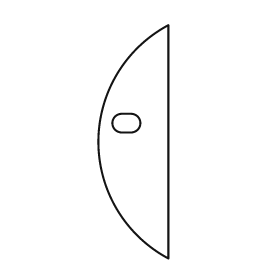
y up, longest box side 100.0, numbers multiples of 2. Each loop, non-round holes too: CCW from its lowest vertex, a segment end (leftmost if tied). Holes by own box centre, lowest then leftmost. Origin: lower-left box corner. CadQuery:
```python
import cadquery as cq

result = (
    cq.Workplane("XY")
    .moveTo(30.0, 0.0)
    .lineTo(30.0, 100.0)
    .threePointArc((0.0, 50.0), (30.0, 0.0))
    .close()
    .moveTo(10.0, 54.0)
    .lineTo(14.0, 54.0)
    .threePointArc((18.0, 58.0), (14.0, 62.0))
    .lineTo(10.0, 62.0)
    .threePointArc((6.0, 58.0), (10.0, 54.0))
    .close()
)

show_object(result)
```